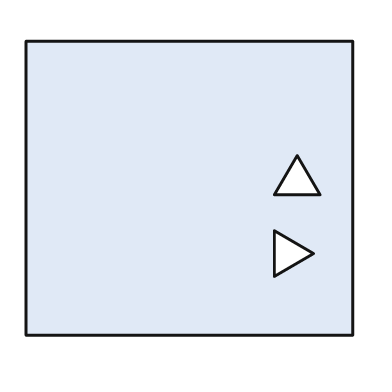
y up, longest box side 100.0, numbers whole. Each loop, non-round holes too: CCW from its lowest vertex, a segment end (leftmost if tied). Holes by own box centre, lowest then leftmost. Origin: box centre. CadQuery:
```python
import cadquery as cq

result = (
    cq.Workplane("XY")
    .moveTo(-50.0, -45.0)
    .lineTo(50.0, -45.0)
    .lineTo(50.0, 45.0)
    .lineTo(-50.0, 45.0)
    .close()
    .moveTo(26.0, -27.0)
    .lineTo(38.0, -20.0)
    .lineTo(26.0, -13.0)
    .close()
    .moveTo(26.0, -2.0)
    .lineTo(40.0, -2.0)
    .lineTo(33.0, 10.0)
    .close()
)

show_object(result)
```